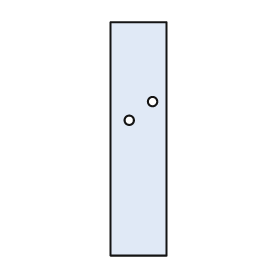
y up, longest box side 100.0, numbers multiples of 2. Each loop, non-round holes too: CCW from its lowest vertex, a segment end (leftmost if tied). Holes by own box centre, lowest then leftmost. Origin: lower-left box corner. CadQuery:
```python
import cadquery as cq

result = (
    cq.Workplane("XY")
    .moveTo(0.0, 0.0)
    .lineTo(24.0, 0.0)
    .lineTo(24.0, 100.0)
    .lineTo(0.0, 100.0)
    .close()
    .moveTo(8.0, 58.0)
    .circle(2.0)
    .moveTo(18.0, 66.0)
    .circle(2.0)
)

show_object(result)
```